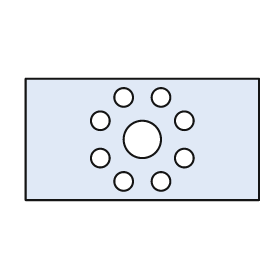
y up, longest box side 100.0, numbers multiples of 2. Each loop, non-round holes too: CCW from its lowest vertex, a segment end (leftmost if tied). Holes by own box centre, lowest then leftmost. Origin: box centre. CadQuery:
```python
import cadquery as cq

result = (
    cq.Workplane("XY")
    .moveTo(-50.0, -26.0)
    .lineTo(50.0, -26.0)
    .lineTo(50.0, 26.0)
    .lineTo(-50.0, 26.0)
    .close()
    .moveTo(-8.0, -18.0)
    .circle(4.0)
    .moveTo(8.0, -18.0)
    .circle(4.0)
    .moveTo(-18.0, -8.0)
    .circle(4.0)
    .moveTo(18.0, -8.0)
    .circle(4.0)
    .moveTo(0.0, 0.0)
    .circle(8.0)
    .moveTo(-18.0, 8.0)
    .circle(4.0)
    .moveTo(18.0, 8.0)
    .circle(4.0)
    .moveTo(-8.0, 18.0)
    .circle(4.0)
    .moveTo(8.0, 18.0)
    .circle(4.0)
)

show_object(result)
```